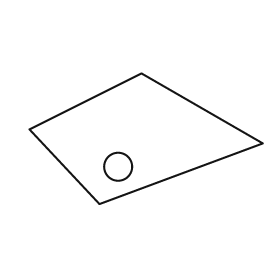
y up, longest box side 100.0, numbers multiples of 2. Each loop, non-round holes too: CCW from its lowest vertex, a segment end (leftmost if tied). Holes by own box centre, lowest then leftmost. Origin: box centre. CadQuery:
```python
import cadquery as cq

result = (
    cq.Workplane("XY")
    .moveTo(-20.0, -28.0)
    .lineTo(50.0, -2.0)
    .lineTo(-2.0, 28.0)
    .lineTo(-50.0, 4.0)
    .close()
    .moveTo(-12.0, -12.0)
    .circle(6.0)
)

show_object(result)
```